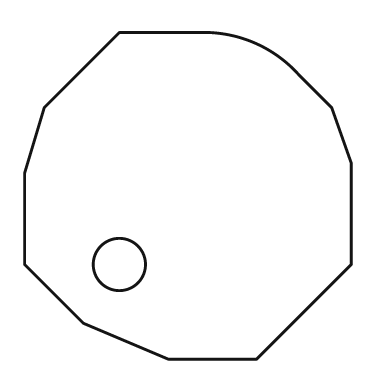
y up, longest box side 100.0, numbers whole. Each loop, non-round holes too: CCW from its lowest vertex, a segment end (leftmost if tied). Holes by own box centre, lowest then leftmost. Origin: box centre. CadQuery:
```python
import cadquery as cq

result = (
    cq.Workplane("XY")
    .moveTo(-6.0, -50.0)
    .lineTo(21.0, -50.0)
    .lineTo(50.0, -21.0)
    .lineTo(50.0, 10.0)
    .lineTo(44.0, 27.0)
    .lineTo(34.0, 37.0)
    .threePointArc((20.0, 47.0), (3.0, 50.0))
    .lineTo(-21.0, 50.0)
    .lineTo(-44.0, 27.0)
    .lineTo(-50.0, 7.0)
    .lineTo(-50.0, -21.0)
    .lineTo(-32.0, -39.0)
    .close()
    .moveTo(-21.0, -21.0)
    .circle(8.0)
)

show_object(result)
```